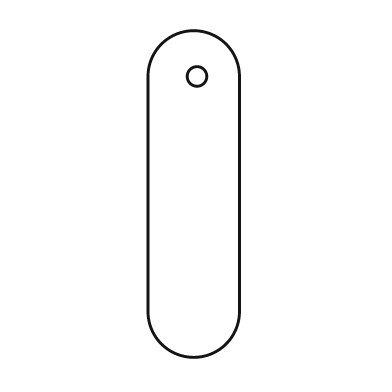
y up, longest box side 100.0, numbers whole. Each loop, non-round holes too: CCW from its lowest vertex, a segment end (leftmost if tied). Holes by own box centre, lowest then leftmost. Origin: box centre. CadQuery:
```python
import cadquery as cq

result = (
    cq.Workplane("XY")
    .moveTo(-14.0, -36.0)
    .threePointArc((0.0, -50.0), (14.0, -36.0))
    .lineTo(14.0, 36.0)
    .threePointArc((0.0, 50.0), (-14.0, 36.0))
    .close()
    .moveTo(1.0, 36.0)
    .circle(3.0)
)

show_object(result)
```